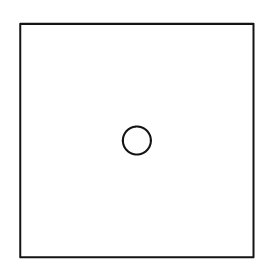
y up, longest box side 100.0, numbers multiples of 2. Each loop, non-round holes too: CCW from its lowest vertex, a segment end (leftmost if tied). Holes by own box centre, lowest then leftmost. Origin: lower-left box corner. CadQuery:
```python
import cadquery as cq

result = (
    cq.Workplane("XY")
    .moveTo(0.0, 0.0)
    .lineTo(100.0, 0.0)
    .lineTo(100.0, 100.0)
    .lineTo(0.0, 100.0)
    .close()
    .moveTo(50.0, 50.0)
    .circle(6.0)
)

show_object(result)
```